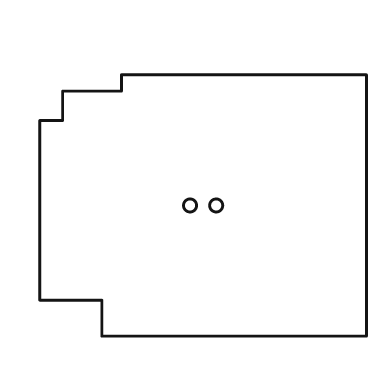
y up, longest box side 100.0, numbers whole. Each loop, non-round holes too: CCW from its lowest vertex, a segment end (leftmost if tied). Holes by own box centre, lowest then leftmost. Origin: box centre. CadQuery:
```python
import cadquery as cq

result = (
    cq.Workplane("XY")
    .moveTo(-31.0, -40.0)
    .lineTo(50.0, -40.0)
    .lineTo(50.0, 40.0)
    .lineTo(-25.0, 40.0)
    .lineTo(-25.0, 35.0)
    .lineTo(-43.0, 35.0)
    .lineTo(-43.0, 26.0)
    .lineTo(-50.0, 26.0)
    .lineTo(-50.0, -29.0)
    .lineTo(-31.0, -29.0)
    .close()
    .moveTo(-4.0, 0.0)
    .circle(2.0)
    .moveTo(4.0, 0.0)
    .circle(2.0)
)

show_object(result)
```